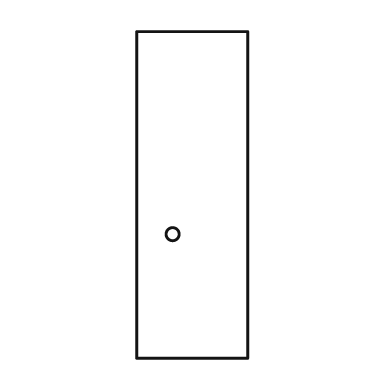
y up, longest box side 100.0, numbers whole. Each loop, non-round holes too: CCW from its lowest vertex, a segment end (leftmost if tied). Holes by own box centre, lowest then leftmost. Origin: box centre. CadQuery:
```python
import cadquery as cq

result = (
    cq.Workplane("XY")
    .moveTo(-17.0, -50.0)
    .lineTo(17.0, -50.0)
    .lineTo(17.0, 50.0)
    .lineTo(-17.0, 50.0)
    .close()
    .moveTo(-6.0, -12.0)
    .circle(2.0)
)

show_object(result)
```